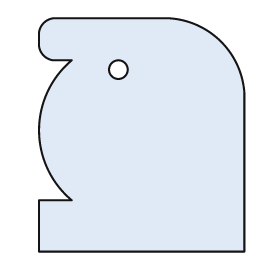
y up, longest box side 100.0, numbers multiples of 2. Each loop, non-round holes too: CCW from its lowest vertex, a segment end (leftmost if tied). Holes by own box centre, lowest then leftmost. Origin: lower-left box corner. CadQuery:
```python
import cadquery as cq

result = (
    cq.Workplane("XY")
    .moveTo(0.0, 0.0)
    .lineTo(88.0, 0.0)
    .lineTo(88.0, 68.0)
    .threePointArc((78.0, 90.0), (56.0, 100.0))
    .lineTo(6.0, 100.0)
    .threePointArc((2.0, 98.0), (0.0, 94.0))
    .lineTo(0.0, 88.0)
    .threePointArc((2.0, 84.0), (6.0, 82.0))
    .lineTo(14.0, 82.0)
    .threePointArc((0.0, 52.0), (14.0, 22.0))
    .lineTo(0.0, 22.0)
    .close()
    .moveTo(34.0, 78.0)
    .circle(4.0)
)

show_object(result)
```